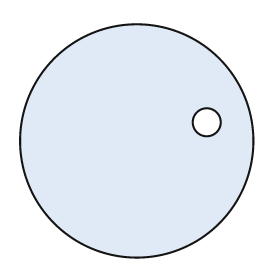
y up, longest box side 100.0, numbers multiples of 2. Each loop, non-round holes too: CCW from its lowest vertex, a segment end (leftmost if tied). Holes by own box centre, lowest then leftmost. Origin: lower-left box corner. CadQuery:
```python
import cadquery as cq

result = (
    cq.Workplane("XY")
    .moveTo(50.0, 50.0)
    .circle(50.0)
    .moveTo(80.0, 58.0)
    .circle(6.0)
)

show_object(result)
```